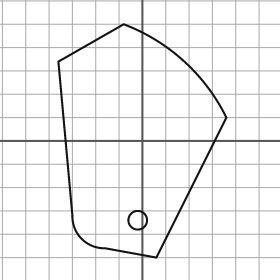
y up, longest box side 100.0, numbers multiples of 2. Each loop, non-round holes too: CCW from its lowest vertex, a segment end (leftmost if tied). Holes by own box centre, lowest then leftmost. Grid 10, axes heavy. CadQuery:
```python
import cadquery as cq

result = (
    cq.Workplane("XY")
    .moveTo(6.0, -50.0)
    .lineTo(36.0, 10.0)
    .threePointArc((18.0, 34.0), (-8.0, 50.0))
    .lineTo(-36.0, 34.0)
    .lineTo(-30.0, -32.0)
    .threePointArc((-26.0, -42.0), (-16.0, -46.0))
    .close()
    .moveTo(-2.0, -34.0)
    .circle(4.0)
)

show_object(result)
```